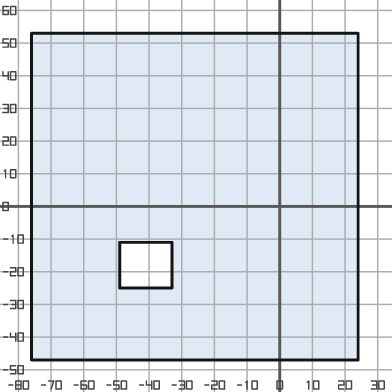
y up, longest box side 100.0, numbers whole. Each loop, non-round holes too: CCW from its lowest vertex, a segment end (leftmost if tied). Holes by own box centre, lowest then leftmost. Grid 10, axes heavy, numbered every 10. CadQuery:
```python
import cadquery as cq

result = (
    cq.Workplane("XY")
    .moveTo(-76.0, -47.0)
    .lineTo(24.0, -47.0)
    .lineTo(24.0, 53.0)
    .lineTo(-76.0, 53.0)
    .close()
    .moveTo(-49.0, -25.0)
    .lineTo(-33.0, -25.0)
    .lineTo(-33.0, -11.0)
    .lineTo(-49.0, -11.0)
    .close()
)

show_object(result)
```